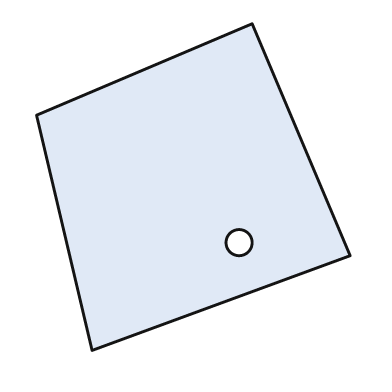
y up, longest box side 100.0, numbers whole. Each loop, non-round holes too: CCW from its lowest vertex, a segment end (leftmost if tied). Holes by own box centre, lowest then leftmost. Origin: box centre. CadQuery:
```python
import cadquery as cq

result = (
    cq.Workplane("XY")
    .moveTo(-31.0, -50.0)
    .lineTo(48.0, -21.0)
    .lineTo(18.0, 50.0)
    .lineTo(-48.0, 22.0)
    .close()
    .moveTo(14.0, -17.0)
    .circle(4.0)
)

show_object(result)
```